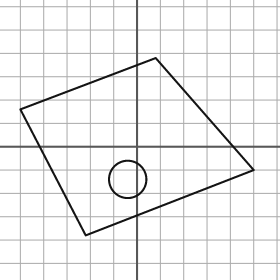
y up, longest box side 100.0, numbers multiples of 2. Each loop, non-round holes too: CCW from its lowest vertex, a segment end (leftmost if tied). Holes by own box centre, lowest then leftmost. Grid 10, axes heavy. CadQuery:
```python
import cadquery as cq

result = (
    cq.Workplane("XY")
    .moveTo(-22.0, -38.0)
    .lineTo(50.0, -10.0)
    .lineTo(8.0, 38.0)
    .lineTo(-50.0, 16.0)
    .close()
    .moveTo(-4.0, -14.0)
    .circle(8.0)
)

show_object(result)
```